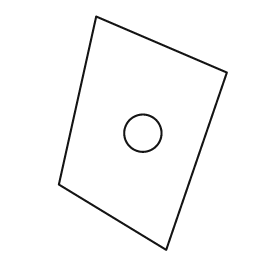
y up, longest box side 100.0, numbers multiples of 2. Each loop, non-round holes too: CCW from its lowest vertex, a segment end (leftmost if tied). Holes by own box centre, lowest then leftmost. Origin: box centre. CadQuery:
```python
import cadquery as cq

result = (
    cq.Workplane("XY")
    .moveTo(10.0, -50.0)
    .lineTo(36.0, 26.0)
    .lineTo(-20.0, 50.0)
    .lineTo(-36.0, -22.0)
    .close()
    .moveTo(0.0, 0.0)
    .circle(8.0)
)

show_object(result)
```